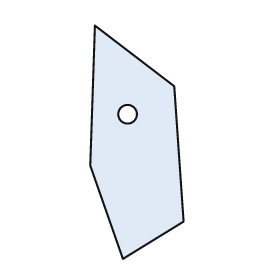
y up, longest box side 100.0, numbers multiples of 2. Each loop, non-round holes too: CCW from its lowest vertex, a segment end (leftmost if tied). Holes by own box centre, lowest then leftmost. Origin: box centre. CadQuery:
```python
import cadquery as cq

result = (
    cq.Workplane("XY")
    .moveTo(-6.0, -50.0)
    .lineTo(20.0, -34.0)
    .lineTo(16.0, 24.0)
    .lineTo(-18.0, 50.0)
    .lineTo(-20.0, -10.0)
    .close()
    .moveTo(-4.0, 12.0)
    .circle(4.0)
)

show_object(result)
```